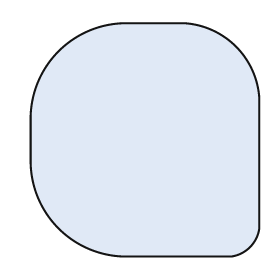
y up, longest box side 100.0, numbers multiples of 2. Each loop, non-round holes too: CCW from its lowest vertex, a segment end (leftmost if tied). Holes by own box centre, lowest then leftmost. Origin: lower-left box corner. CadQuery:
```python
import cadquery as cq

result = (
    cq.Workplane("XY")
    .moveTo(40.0, 0.0)
    .lineTo(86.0, 0.0)
    .threePointArc((94.0, 4.0), (98.0, 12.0))
    .lineTo(98.0, 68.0)
    .threePointArc((88.0, 90.0), (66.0, 100.0))
    .lineTo(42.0, 100.0)
    .threePointArc((12.0, 88.0), (0.0, 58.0))
    .lineTo(0.0, 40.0)
    .threePointArc((12.0, 12.0), (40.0, 0.0))
    .close()
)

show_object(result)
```